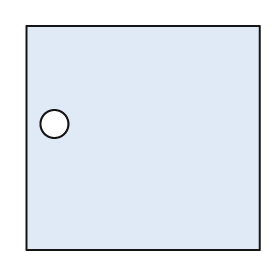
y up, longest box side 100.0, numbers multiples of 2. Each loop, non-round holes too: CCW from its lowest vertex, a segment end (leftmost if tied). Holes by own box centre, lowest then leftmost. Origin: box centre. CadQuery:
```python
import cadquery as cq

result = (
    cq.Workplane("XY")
    .moveTo(-50.0, -48.0)
    .lineTo(50.0, -48.0)
    .lineTo(50.0, 48.0)
    .lineTo(-50.0, 48.0)
    .close()
    .moveTo(-38.0, 6.0)
    .circle(6.0)
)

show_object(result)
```